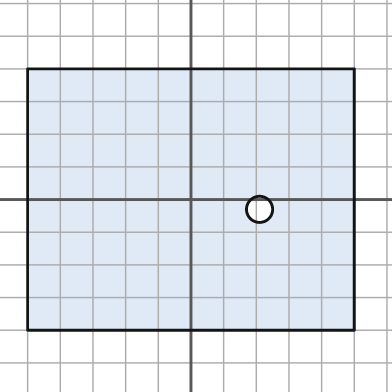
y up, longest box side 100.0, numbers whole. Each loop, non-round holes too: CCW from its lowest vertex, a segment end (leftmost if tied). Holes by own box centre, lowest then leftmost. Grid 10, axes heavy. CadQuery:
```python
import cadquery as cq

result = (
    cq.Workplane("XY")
    .moveTo(-50.0, -40.0)
    .lineTo(50.0, -40.0)
    .lineTo(50.0, 40.0)
    .lineTo(-50.0, 40.0)
    .close()
    .moveTo(21.0, -3.0)
    .circle(4.0)
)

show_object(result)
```